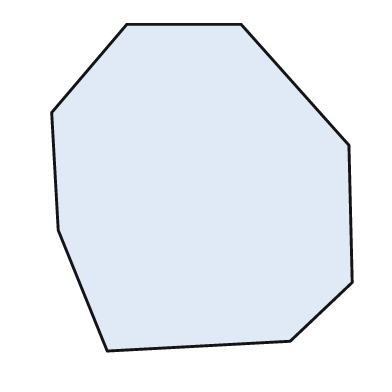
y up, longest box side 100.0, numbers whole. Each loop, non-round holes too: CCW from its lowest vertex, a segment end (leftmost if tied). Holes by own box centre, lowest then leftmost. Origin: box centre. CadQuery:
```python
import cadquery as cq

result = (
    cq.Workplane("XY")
    .moveTo(-29.0, -50.0)
    .lineTo(27.0, -47.0)
    .lineTo(46.0, -29.0)
    .lineTo(45.0, 13.0)
    .lineTo(12.0, 50.0)
    .lineTo(-23.0, 50.0)
    .lineTo(-46.0, 23.0)
    .lineTo(-44.0, -13.0)
    .close()
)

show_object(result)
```